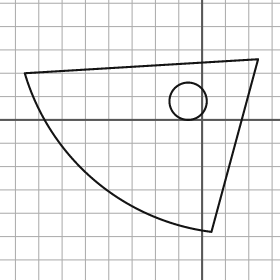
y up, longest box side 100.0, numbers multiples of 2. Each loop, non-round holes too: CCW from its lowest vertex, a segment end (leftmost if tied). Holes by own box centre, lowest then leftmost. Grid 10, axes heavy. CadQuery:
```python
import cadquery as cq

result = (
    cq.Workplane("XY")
    .moveTo(4.0, -48.0)
    .lineTo(24.0, 26.0)
    .lineTo(-76.0, 20.0)
    .threePointArc((-46.0, -26.0), (4.0, -48.0))
    .close()
    .moveTo(-6.0, 8.0)
    .circle(8.0)
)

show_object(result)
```